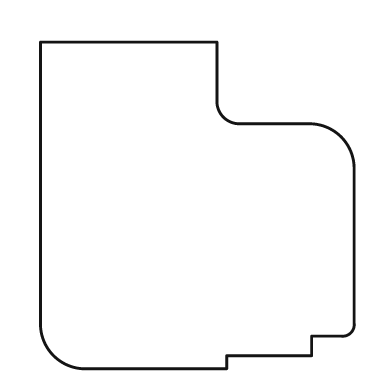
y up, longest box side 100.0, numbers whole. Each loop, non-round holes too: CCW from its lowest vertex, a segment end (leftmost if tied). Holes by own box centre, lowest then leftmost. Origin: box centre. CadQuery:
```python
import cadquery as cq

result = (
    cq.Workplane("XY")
    .moveTo(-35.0, -50.0)
    .lineTo(9.0, -50.0)
    .lineTo(9.0, -46.0)
    .lineTo(35.0, -46.0)
    .lineTo(35.0, -40.0)
    .lineTo(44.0, -40.0)
    .threePointArc((47.0, -39.0), (48.0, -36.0))
    .lineTo(48.0, 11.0)
    .threePointArc((44.0, 21.0), (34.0, 25.0))
    .lineTo(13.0, 25.0)
    .threePointArc((8.0, 27.0), (6.0, 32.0))
    .lineTo(6.0, 50.0)
    .lineTo(-48.0, 50.0)
    .lineTo(-48.0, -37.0)
    .threePointArc((-44.0, -46.0), (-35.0, -50.0))
    .close()
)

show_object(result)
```